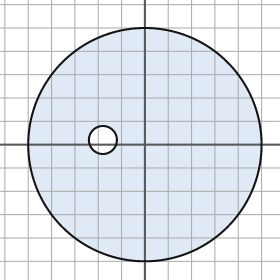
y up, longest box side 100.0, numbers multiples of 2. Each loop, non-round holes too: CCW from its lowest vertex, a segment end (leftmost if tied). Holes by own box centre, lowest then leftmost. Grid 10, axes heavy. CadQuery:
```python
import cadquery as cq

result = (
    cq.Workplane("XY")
    .moveTo(0.0, 0.0)
    .circle(50.0)
    .moveTo(-18.0, 2.0)
    .circle(6.0)
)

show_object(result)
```